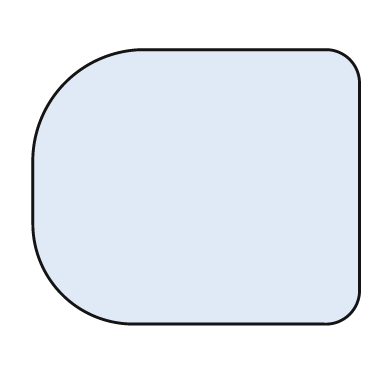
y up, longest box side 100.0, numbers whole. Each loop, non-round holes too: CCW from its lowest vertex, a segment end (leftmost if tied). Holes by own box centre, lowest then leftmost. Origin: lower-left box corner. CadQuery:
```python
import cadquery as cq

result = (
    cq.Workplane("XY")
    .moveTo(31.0, 0.0)
    .lineTo(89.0, 0.0)
    .threePointArc((97.0, 3.0), (100.0, 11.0))
    .lineTo(100.0, 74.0)
    .threePointArc((97.0, 81.0), (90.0, 84.0))
    .lineTo(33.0, 84.0)
    .threePointArc((10.0, 74.0), (0.0, 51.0))
    .lineTo(0.0, 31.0)
    .threePointArc((9.0, 9.0), (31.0, 0.0))
    .close()
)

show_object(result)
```